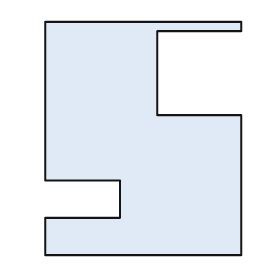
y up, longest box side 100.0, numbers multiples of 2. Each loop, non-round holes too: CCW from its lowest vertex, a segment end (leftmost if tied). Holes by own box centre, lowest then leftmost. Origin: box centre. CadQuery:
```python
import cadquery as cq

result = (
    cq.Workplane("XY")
    .moveTo(-42.0, -50.0)
    .lineTo(42.0, -50.0)
    .lineTo(42.0, 10.0)
    .lineTo(6.0, 10.0)
    .lineTo(6.0, 46.0)
    .lineTo(42.0, 46.0)
    .lineTo(42.0, 50.0)
    .lineTo(-42.0, 50.0)
    .lineTo(-42.0, -18.0)
    .lineTo(-10.0, -18.0)
    .lineTo(-10.0, -34.0)
    .lineTo(-42.0, -34.0)
    .close()
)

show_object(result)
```